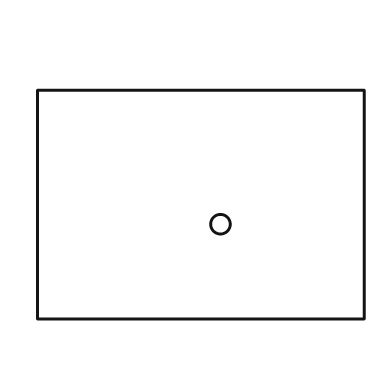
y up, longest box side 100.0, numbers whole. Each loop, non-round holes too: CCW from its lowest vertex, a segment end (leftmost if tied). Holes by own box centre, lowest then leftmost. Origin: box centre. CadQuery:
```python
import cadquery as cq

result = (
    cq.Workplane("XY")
    .moveTo(-50.0, -35.0)
    .lineTo(50.0, -35.0)
    .lineTo(50.0, 35.0)
    .lineTo(-50.0, 35.0)
    .close()
    .moveTo(6.0, -6.0)
    .circle(3.0)
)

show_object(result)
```